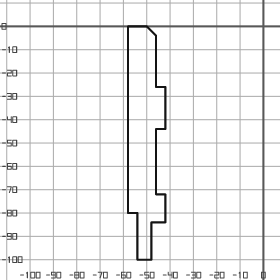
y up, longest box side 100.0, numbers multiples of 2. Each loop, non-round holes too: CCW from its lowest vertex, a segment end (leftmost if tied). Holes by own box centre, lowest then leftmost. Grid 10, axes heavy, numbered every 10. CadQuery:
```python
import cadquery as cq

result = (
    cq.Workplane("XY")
    .moveTo(-54.0, -100.0)
    .lineTo(-48.0, -100.0)
    .lineTo(-48.0, -84.0)
    .lineTo(-42.0, -84.0)
    .lineTo(-42.0, -72.0)
    .lineTo(-46.0, -72.0)
    .lineTo(-46.0, -44.0)
    .lineTo(-42.0, -44.0)
    .lineTo(-42.0, -26.0)
    .lineTo(-46.0, -26.0)
    .lineTo(-46.0, -4.0)
    .lineTo(-50.0, 0.0)
    .lineTo(-58.0, 0.0)
    .lineTo(-58.0, -80.0)
    .lineTo(-54.0, -80.0)
    .close()
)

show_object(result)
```